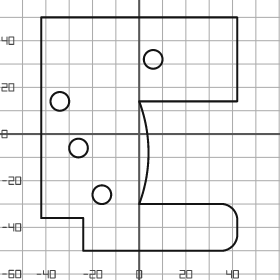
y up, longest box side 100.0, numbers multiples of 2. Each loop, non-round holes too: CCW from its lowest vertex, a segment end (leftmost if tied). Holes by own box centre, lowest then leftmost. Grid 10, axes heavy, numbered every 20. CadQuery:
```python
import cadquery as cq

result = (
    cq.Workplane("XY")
    .moveTo(-24.0, -50.0)
    .lineTo(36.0, -50.0)
    .threePointArc((40.0, -48.0), (42.0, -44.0))
    .lineTo(42.0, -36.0)
    .threePointArc((40.0, -32.0), (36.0, -30.0))
    .lineTo(0.0, -30.0)
    .threePointArc((4.0, -8.0), (0.0, 14.0))
    .lineTo(42.0, 14.0)
    .lineTo(42.0, 50.0)
    .lineTo(-42.0, 50.0)
    .lineTo(-42.0, -36.0)
    .lineTo(-24.0, -36.0)
    .close()
    .moveTo(-16.0, -26.0)
    .circle(4.0)
    .moveTo(-26.0, -6.0)
    .circle(4.0)
    .moveTo(-34.0, 14.0)
    .circle(4.0)
    .moveTo(6.0, 32.0)
    .circle(4.0)
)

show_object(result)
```